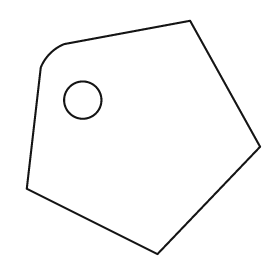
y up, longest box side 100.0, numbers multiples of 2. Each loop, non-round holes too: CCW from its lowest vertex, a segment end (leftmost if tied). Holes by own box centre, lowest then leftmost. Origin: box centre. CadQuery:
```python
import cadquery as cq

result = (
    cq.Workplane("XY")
    .moveTo(6.0, -50.0)
    .lineTo(50.0, -4.0)
    .lineTo(20.0, 50.0)
    .lineTo(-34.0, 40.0)
    .threePointArc((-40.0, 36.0), (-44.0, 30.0))
    .lineTo(-50.0, -22.0)
    .close()
    .moveTo(-26.0, 16.0)
    .circle(8.0)
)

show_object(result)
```